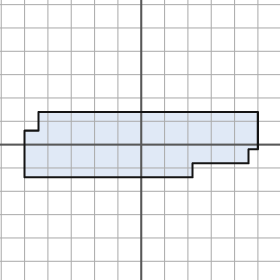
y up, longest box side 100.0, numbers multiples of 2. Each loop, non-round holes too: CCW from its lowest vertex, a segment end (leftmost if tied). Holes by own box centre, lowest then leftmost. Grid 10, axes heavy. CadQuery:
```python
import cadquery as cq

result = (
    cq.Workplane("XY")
    .moveTo(-50.0, -14.0)
    .lineTo(22.0, -14.0)
    .lineTo(22.0, -8.0)
    .lineTo(46.0, -8.0)
    .lineTo(46.0, -2.0)
    .lineTo(50.0, -2.0)
    .lineTo(50.0, 14.0)
    .lineTo(-44.0, 14.0)
    .lineTo(-44.0, 6.0)
    .lineTo(-50.0, 6.0)
    .close()
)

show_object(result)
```